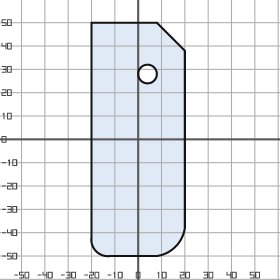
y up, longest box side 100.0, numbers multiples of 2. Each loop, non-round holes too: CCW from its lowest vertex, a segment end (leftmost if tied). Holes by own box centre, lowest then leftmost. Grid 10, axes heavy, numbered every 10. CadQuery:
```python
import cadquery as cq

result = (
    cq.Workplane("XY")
    .moveTo(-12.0, -50.0)
    .lineTo(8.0, -50.0)
    .threePointArc((16.0, -46.0), (20.0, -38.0))
    .lineTo(20.0, 38.0)
    .lineTo(8.0, 50.0)
    .lineTo(-20.0, 50.0)
    .lineTo(-20.0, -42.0)
    .threePointArc((-18.0, -48.0), (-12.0, -50.0))
    .close()
    .moveTo(4.0, 28.0)
    .circle(4.0)
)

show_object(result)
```